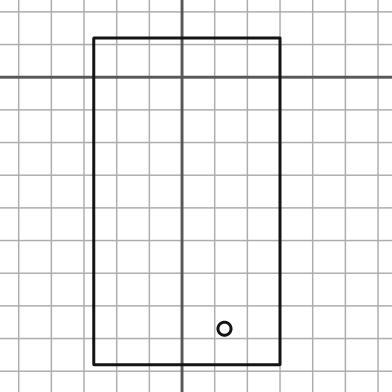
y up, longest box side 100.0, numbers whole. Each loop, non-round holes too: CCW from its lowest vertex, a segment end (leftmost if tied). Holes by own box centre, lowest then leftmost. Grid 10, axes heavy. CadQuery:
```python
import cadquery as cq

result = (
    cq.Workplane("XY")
    .moveTo(-27.0, -88.0)
    .lineTo(30.0, -88.0)
    .lineTo(30.0, 12.0)
    .lineTo(-27.0, 12.0)
    .close()
    .moveTo(13.0, -77.0)
    .circle(2.0)
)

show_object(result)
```